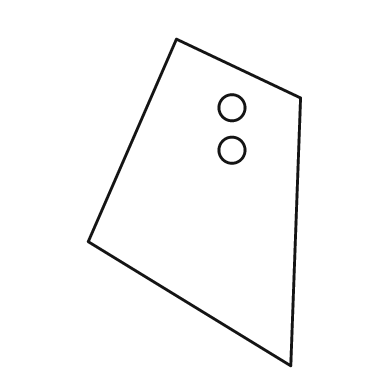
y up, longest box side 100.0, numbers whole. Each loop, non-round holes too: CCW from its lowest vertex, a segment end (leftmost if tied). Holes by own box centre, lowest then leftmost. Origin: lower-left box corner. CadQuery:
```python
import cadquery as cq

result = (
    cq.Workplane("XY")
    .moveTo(62.0, 0.0)
    .lineTo(65.0, 82.0)
    .lineTo(27.0, 100.0)
    .lineTo(0.0, 38.0)
    .close()
    .moveTo(44.0, 66.0)
    .circle(4.0)
    .moveTo(44.0, 79.0)
    .circle(4.0)
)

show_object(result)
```